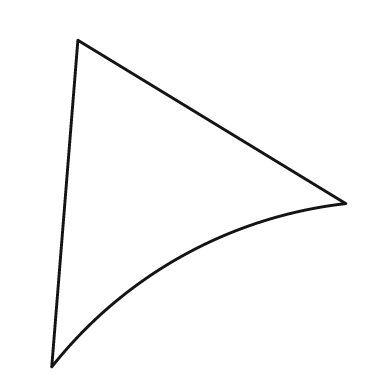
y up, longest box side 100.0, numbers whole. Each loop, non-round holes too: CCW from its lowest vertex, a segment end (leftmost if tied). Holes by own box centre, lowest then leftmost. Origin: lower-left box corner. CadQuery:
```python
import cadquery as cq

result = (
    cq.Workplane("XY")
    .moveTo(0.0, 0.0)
    .threePointArc((40.0, 34.0), (90.0, 50.0))
    .lineTo(8.0, 100.0)
    .close()
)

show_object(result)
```